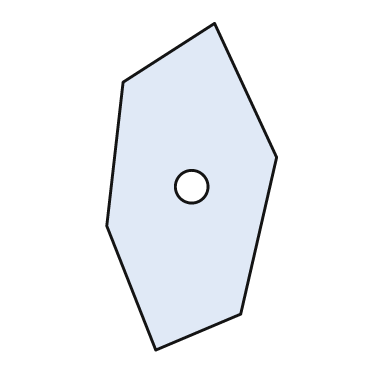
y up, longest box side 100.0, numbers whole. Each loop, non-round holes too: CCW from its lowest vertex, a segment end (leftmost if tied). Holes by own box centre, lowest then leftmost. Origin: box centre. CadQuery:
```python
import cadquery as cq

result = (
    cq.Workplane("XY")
    .moveTo(-11.0, -50.0)
    .lineTo(15.0, -39.0)
    .lineTo(26.0, 9.0)
    .lineTo(7.0, 50.0)
    .lineTo(-21.0, 32.0)
    .lineTo(-26.0, -12.0)
    .close()
    .moveTo(0.0, 0.0)
    .circle(5.0)
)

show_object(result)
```